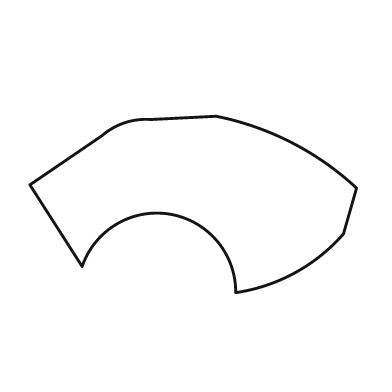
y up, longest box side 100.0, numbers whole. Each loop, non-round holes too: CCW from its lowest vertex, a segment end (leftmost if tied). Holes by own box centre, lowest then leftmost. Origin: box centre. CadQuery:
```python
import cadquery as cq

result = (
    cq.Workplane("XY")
    .moveTo(13.0, -27.0)
    .threePointArc((31.0, -21.0), (46.0, -9.0))
    .lineTo(50.0, 5.0)
    .threePointArc((30.0, 19.0), (7.0, 27.0))
    .lineTo(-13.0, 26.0)
    .threePointArc((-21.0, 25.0), (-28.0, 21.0))
    .lineTo(-50.0, 6.0)
    .lineTo(-34.0, -19.0)
    .threePointArc((-7.0, -3.0), (13.0, -27.0))
    .close()
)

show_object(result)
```